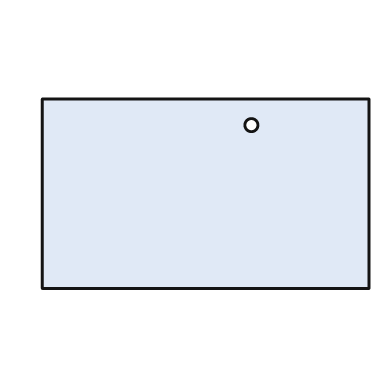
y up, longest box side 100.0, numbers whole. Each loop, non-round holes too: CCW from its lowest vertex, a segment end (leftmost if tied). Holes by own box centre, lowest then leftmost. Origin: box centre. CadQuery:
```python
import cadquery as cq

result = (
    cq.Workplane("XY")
    .moveTo(-50.0, -29.0)
    .lineTo(50.0, -29.0)
    .lineTo(50.0, 29.0)
    .lineTo(-50.0, 29.0)
    .close()
    .moveTo(14.0, 21.0)
    .circle(2.0)
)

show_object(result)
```